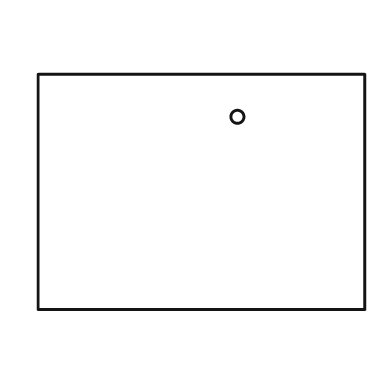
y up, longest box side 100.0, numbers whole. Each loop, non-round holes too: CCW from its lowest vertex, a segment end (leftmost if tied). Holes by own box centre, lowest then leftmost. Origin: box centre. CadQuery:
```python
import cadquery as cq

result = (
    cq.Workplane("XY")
    .moveTo(-50.0, -36.0)
    .lineTo(50.0, -36.0)
    .lineTo(50.0, 36.0)
    .lineTo(-50.0, 36.0)
    .close()
    .moveTo(11.0, 23.0)
    .circle(2.0)
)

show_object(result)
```